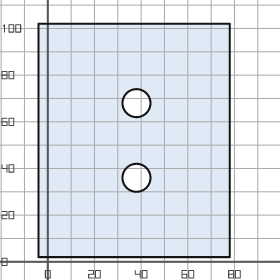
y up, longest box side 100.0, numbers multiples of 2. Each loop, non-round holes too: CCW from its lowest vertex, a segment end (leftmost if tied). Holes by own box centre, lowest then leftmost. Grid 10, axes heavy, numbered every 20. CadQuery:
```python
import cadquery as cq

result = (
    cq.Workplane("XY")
    .moveTo(-4.0, 2.0)
    .lineTo(78.0, 2.0)
    .lineTo(78.0, 102.0)
    .lineTo(-4.0, 102.0)
    .close()
    .moveTo(38.0, 36.0)
    .circle(6.0)
    .moveTo(38.0, 68.0)
    .circle(6.0)
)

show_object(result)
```